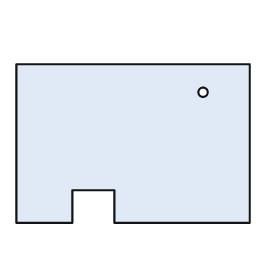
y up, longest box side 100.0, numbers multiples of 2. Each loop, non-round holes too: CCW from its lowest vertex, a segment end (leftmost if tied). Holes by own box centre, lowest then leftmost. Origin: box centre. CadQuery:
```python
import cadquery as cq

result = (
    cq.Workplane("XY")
    .moveTo(-50.0, -34.0)
    .lineTo(-26.0, -34.0)
    .lineTo(-26.0, -20.0)
    .lineTo(-8.0, -20.0)
    .lineTo(-8.0, -34.0)
    .lineTo(50.0, -34.0)
    .lineTo(50.0, 34.0)
    .lineTo(-50.0, 34.0)
    .close()
    .moveTo(30.0, 22.0)
    .circle(2.0)
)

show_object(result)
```